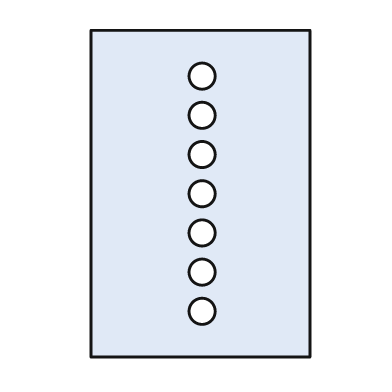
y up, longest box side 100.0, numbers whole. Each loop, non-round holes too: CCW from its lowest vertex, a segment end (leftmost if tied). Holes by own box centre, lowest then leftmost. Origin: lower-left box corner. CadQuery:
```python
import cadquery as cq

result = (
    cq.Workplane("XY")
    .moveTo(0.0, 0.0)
    .lineTo(67.0, 0.0)
    .lineTo(67.0, 100.0)
    .lineTo(0.0, 100.0)
    .close()
    .moveTo(34.0, 14.0)
    .circle(4.0)
    .moveTo(34.0, 26.0)
    .circle(4.0)
    .moveTo(34.0, 38.0)
    .circle(4.0)
    .moveTo(34.0, 50.0)
    .circle(4.0)
    .moveTo(34.0, 62.0)
    .circle(4.0)
    .moveTo(34.0, 74.0)
    .circle(4.0)
    .moveTo(34.0, 86.0)
    .circle(4.0)
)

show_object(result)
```